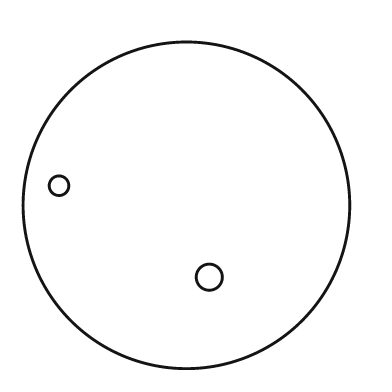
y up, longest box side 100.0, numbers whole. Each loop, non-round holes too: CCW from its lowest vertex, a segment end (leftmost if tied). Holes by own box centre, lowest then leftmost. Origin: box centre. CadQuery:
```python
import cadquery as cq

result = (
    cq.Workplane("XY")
    .moveTo(0.0, 0.0)
    .circle(50.0)
    .moveTo(7.0, -22.0)
    .circle(4.0)
    .moveTo(-39.0, 6.0)
    .circle(3.0)
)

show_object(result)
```